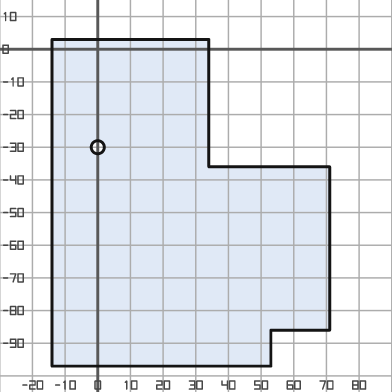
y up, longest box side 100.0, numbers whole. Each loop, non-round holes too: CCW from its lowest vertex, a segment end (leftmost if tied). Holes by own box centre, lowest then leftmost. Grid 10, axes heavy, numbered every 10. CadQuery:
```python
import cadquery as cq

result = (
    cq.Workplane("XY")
    .moveTo(-14.0, -97.0)
    .lineTo(53.0, -97.0)
    .lineTo(53.0, -86.0)
    .lineTo(71.0, -86.0)
    .lineTo(71.0, -36.0)
    .lineTo(34.0, -36.0)
    .lineTo(34.0, 3.0)
    .lineTo(-14.0, 3.0)
    .close()
    .moveTo(0.0, -30.0)
    .circle(2.0)
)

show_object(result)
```